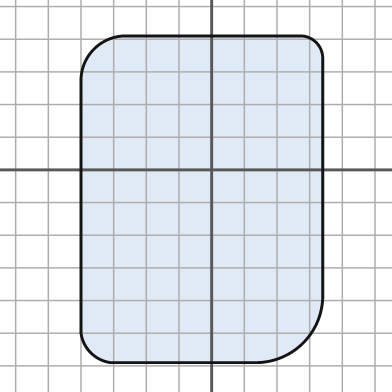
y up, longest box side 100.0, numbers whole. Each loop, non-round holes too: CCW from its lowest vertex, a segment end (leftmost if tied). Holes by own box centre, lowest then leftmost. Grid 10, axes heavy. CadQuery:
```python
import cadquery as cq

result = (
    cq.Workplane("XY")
    .moveTo(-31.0, -59.0)
    .lineTo(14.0, -59.0)
    .threePointArc((28.0, -53.0), (34.0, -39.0))
    .lineTo(34.0, 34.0)
    .threePointArc((32.0, 39.0), (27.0, 41.0))
    .lineTo(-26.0, 41.0)
    .threePointArc((-36.0, 37.0), (-40.0, 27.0))
    .lineTo(-40.0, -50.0)
    .threePointArc((-37.0, -56.0), (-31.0, -59.0))
    .close()
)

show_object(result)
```